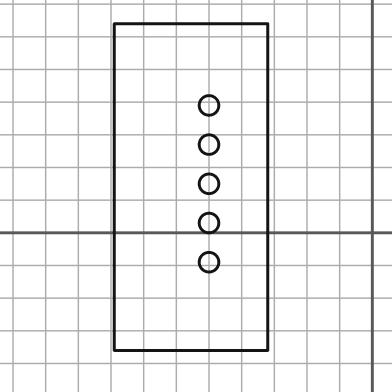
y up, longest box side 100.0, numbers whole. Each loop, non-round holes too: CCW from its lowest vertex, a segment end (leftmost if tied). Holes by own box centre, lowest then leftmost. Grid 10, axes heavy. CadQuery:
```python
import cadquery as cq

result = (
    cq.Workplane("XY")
    .moveTo(-79.0, -36.0)
    .lineTo(-32.0, -36.0)
    .lineTo(-32.0, 64.0)
    .lineTo(-79.0, 64.0)
    .close()
    .moveTo(-50.0, -9.0)
    .circle(3.0)
    .moveTo(-50.0, 3.0)
    .circle(3.0)
    .moveTo(-50.0, 15.0)
    .circle(3.0)
    .moveTo(-50.0, 27.0)
    .circle(3.0)
    .moveTo(-50.0, 39.0)
    .circle(3.0)
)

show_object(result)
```